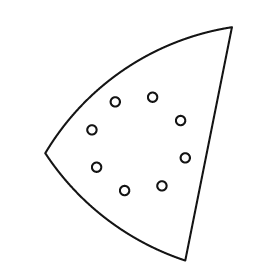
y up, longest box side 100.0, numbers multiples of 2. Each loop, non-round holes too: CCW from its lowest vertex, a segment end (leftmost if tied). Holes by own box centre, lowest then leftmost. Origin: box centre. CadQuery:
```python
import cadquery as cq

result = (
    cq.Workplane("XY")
    .moveTo(20.0, -50.0)
    .lineTo(40.0, 50.0)
    .threePointArc((-6.0, 32.0), (-40.0, -4.0))
    .threePointArc((-14.0, -32.0), (20.0, -50.0))
    .close()
    .moveTo(-6.0, -20.0)
    .circle(2.0)
    .moveTo(10.0, -18.0)
    .circle(2.0)
    .moveTo(-18.0, -10.0)
    .circle(2.0)
    .moveTo(20.0, -6.0)
    .circle(2.0)
    .moveTo(-20.0, 6.0)
    .circle(2.0)
    .moveTo(18.0, 10.0)
    .circle(2.0)
    .moveTo(-10.0, 18.0)
    .circle(2.0)
    .moveTo(6.0, 20.0)
    .circle(2.0)
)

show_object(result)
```